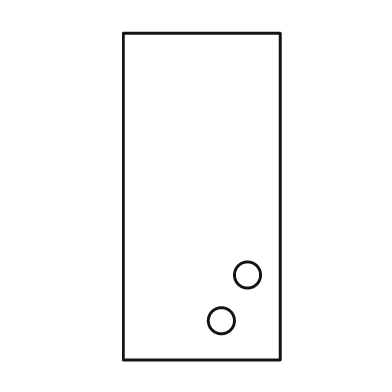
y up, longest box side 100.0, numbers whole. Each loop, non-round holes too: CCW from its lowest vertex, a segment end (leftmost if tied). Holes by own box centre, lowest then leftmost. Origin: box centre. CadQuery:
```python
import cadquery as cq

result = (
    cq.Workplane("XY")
    .moveTo(-24.0, -50.0)
    .lineTo(24.0, -50.0)
    .lineTo(24.0, 50.0)
    .lineTo(-24.0, 50.0)
    .close()
    .moveTo(6.0, -38.0)
    .circle(4.0)
    .moveTo(14.0, -24.0)
    .circle(4.0)
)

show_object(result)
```